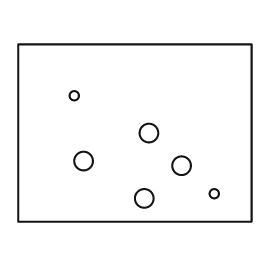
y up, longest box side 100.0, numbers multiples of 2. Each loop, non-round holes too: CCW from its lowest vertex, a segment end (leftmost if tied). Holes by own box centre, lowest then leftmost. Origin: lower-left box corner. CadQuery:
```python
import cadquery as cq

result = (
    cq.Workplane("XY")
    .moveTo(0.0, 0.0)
    .lineTo(100.0, 0.0)
    .lineTo(100.0, 76.0)
    .lineTo(0.0, 76.0)
    .close()
    .moveTo(54.0, 10.0)
    .circle(4.0)
    .moveTo(84.0, 12.0)
    .circle(2.0)
    .moveTo(70.0, 24.0)
    .circle(4.0)
    .moveTo(28.0, 26.0)
    .circle(4.0)
    .moveTo(56.0, 38.0)
    .circle(4.0)
    .moveTo(24.0, 54.0)
    .circle(2.0)
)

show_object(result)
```